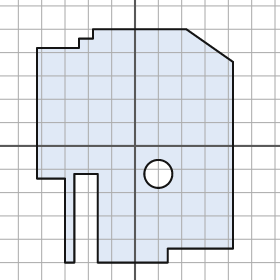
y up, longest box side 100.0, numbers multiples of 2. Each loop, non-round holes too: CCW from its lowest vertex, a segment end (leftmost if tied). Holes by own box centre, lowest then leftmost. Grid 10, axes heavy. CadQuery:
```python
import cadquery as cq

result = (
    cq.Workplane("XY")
    .moveTo(-30.0, -50.0)
    .lineTo(-26.0, -50.0)
    .lineTo(-26.0, -12.0)
    .lineTo(-16.0, -12.0)
    .lineTo(-16.0, -50.0)
    .lineTo(14.0, -50.0)
    .lineTo(14.0, -44.0)
    .lineTo(42.0, -44.0)
    .lineTo(42.0, 36.0)
    .lineTo(22.0, 50.0)
    .lineTo(-18.0, 50.0)
    .lineTo(-18.0, 46.0)
    .lineTo(-24.0, 46.0)
    .lineTo(-24.0, 42.0)
    .lineTo(-42.0, 42.0)
    .lineTo(-42.0, -14.0)
    .lineTo(-30.0, -14.0)
    .close()
    .moveTo(10.0, -12.0)
    .circle(6.0)
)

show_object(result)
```